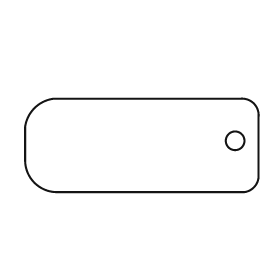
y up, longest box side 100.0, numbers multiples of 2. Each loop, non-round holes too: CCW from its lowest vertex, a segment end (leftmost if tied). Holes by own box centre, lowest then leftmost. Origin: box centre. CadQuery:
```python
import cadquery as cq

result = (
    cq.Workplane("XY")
    .moveTo(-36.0, -20.0)
    .lineTo(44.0, -20.0)
    .threePointArc((48.0, -18.0), (50.0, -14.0))
    .lineTo(50.0, 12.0)
    .threePointArc((48.0, 18.0), (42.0, 20.0))
    .lineTo(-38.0, 20.0)
    .threePointArc((-46.0, 16.0), (-50.0, 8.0))
    .lineTo(-50.0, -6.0)
    .threePointArc((-46.0, -16.0), (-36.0, -20.0))
    .close()
    .moveTo(40.0, 2.0)
    .circle(4.0)
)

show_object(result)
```